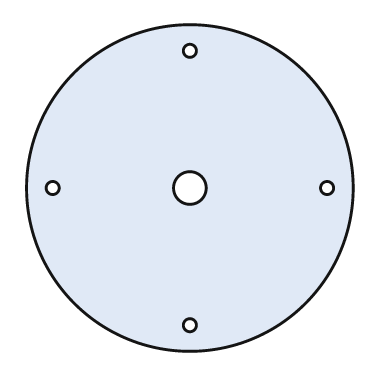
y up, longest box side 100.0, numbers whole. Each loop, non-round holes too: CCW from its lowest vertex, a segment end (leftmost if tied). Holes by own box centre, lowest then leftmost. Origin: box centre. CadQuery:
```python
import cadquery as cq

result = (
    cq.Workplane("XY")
    .moveTo(0.0, 0.0)
    .circle(50.0)
    .moveTo(0.0, -42.0)
    .circle(2.0)
    .moveTo(-42.0, 0.0)
    .circle(2.0)
    .moveTo(0.0, 0.0)
    .circle(5.0)
    .moveTo(42.0, 0.0)
    .circle(2.0)
    .moveTo(0.0, 42.0)
    .circle(2.0)
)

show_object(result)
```